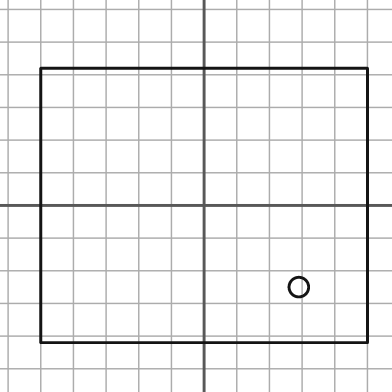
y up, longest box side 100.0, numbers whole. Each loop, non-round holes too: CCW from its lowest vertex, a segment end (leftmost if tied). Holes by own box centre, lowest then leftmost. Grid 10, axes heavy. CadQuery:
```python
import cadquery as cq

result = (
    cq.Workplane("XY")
    .moveTo(-50.0, -42.0)
    .lineTo(50.0, -42.0)
    .lineTo(50.0, 42.0)
    .lineTo(-50.0, 42.0)
    .close()
    .moveTo(29.0, -25.0)
    .circle(3.0)
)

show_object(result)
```